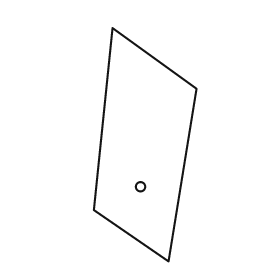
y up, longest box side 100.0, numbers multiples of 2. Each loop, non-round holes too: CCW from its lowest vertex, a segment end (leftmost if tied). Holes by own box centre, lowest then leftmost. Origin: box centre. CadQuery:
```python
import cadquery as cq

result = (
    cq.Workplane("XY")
    .moveTo(10.0, -50.0)
    .lineTo(22.0, 24.0)
    .lineTo(-14.0, 50.0)
    .lineTo(-22.0, -28.0)
    .close()
    .moveTo(-2.0, -18.0)
    .circle(2.0)
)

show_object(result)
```